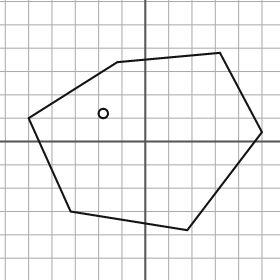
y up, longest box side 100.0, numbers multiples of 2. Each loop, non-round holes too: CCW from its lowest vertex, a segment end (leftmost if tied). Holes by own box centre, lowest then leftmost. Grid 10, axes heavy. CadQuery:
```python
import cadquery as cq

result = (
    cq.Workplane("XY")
    .moveTo(18.0, -38.0)
    .lineTo(50.0, 4.0)
    .lineTo(32.0, 38.0)
    .lineTo(-12.0, 34.0)
    .lineTo(-50.0, 10.0)
    .lineTo(-32.0, -30.0)
    .close()
    .moveTo(-18.0, 12.0)
    .circle(2.0)
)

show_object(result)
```